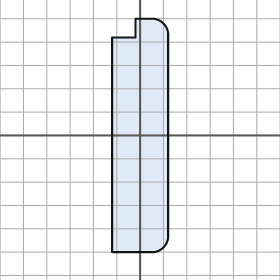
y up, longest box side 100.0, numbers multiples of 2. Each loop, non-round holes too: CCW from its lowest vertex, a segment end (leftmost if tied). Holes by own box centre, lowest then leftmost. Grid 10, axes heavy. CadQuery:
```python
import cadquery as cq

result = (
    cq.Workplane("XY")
    .moveTo(-12.0, -50.0)
    .lineTo(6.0, -50.0)
    .threePointArc((10.0, -48.0), (12.0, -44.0))
    .lineTo(12.0, 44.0)
    .threePointArc((10.0, 48.0), (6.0, 50.0))
    .lineTo(-2.0, 50.0)
    .lineTo(-2.0, 42.0)
    .lineTo(-12.0, 42.0)
    .close()
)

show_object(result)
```